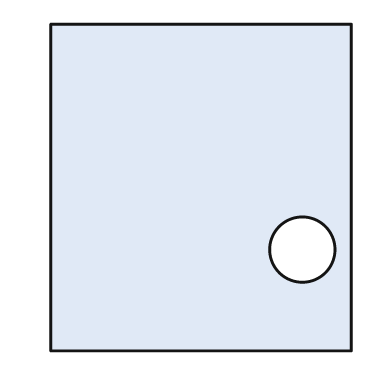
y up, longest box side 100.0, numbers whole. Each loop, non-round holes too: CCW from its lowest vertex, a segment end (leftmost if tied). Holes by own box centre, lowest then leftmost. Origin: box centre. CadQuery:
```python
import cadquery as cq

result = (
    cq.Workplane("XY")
    .moveTo(-46.0, -50.0)
    .lineTo(46.0, -50.0)
    .lineTo(46.0, 50.0)
    .lineTo(-46.0, 50.0)
    .close()
    .moveTo(31.0, -19.0)
    .circle(10.0)
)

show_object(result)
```